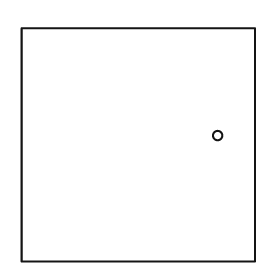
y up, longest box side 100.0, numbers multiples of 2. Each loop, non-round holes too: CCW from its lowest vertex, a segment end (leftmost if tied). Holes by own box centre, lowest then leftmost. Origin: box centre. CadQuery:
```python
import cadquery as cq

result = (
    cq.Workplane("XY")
    .moveTo(-50.0, -50.0)
    .lineTo(50.0, -50.0)
    .lineTo(50.0, 50.0)
    .lineTo(-50.0, 50.0)
    .close()
    .moveTo(34.0, 4.0)
    .circle(2.0)
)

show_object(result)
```